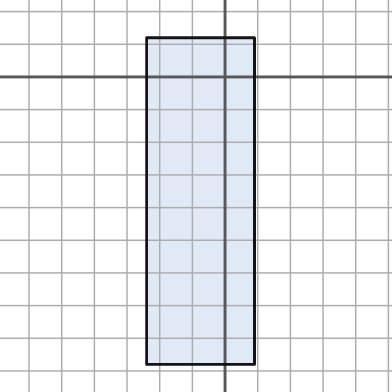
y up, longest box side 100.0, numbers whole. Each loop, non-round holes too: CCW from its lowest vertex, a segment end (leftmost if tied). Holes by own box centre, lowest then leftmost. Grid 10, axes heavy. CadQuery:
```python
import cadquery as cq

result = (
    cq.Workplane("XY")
    .moveTo(-24.0, -88.0)
    .lineTo(9.0, -88.0)
    .lineTo(9.0, 12.0)
    .lineTo(-24.0, 12.0)
    .close()
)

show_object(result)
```